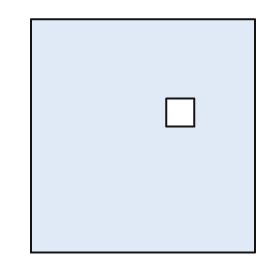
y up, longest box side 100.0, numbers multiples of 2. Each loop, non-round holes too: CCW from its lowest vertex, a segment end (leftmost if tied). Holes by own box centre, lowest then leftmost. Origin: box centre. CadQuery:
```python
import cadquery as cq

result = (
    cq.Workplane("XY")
    .moveTo(-48.0, -50.0)
    .lineTo(48.0, -50.0)
    .lineTo(48.0, 50.0)
    .lineTo(-48.0, 50.0)
    .close()
    .moveTo(10.0, 4.0)
    .lineTo(22.0, 4.0)
    .lineTo(22.0, 16.0)
    .lineTo(10.0, 16.0)
    .close()
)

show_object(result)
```